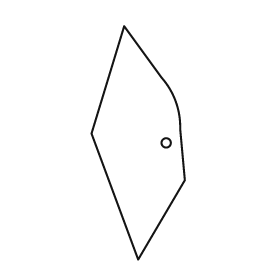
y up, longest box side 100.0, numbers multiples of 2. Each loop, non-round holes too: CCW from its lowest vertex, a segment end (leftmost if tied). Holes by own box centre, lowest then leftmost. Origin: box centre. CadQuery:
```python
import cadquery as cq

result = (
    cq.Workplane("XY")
    .moveTo(0.0, -50.0)
    .lineTo(20.0, -16.0)
    .lineTo(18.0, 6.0)
    .threePointArc((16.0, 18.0), (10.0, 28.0))
    .lineTo(-6.0, 50.0)
    .lineTo(-20.0, 4.0)
    .close()
    .moveTo(12.0, 0.0)
    .circle(2.0)
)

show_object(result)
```